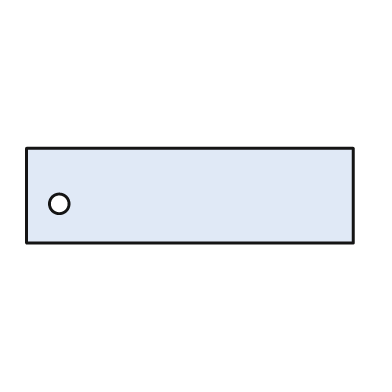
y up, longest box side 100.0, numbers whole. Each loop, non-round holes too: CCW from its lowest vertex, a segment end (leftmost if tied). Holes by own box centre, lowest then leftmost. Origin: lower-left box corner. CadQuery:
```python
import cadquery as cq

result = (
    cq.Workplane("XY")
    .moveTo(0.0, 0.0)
    .lineTo(100.0, 0.0)
    .lineTo(100.0, 29.0)
    .lineTo(0.0, 29.0)
    .close()
    .moveTo(10.0, 12.0)
    .circle(3.0)
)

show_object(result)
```